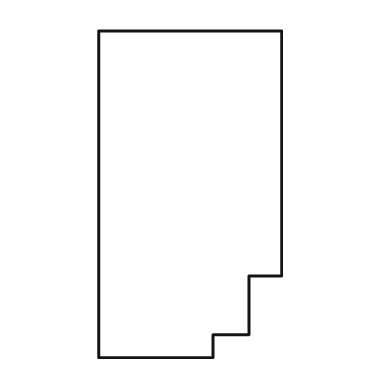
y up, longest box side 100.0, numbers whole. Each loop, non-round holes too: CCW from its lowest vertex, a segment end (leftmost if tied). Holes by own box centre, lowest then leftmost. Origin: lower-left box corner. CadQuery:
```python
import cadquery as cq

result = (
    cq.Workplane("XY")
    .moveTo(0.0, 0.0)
    .lineTo(35.0, 0.0)
    .lineTo(35.0, 7.0)
    .lineTo(46.0, 7.0)
    .lineTo(46.0, 25.0)
    .lineTo(56.0, 25.0)
    .lineTo(56.0, 100.0)
    .lineTo(0.0, 100.0)
    .close()
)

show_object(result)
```